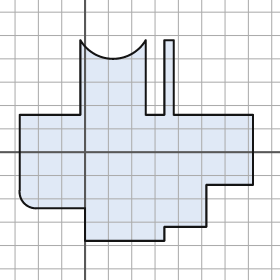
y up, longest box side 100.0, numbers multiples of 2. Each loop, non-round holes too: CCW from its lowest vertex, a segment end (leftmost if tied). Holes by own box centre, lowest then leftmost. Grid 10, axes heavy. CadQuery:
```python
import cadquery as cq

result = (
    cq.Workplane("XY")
    .moveTo(0.0, -38.0)
    .lineTo(34.0, -38.0)
    .lineTo(34.0, -32.0)
    .lineTo(52.0, -32.0)
    .lineTo(52.0, -14.0)
    .lineTo(72.0, -14.0)
    .lineTo(72.0, 16.0)
    .lineTo(38.0, 16.0)
    .lineTo(38.0, 48.0)
    .lineTo(34.0, 48.0)
    .lineTo(34.0, 16.0)
    .lineTo(26.0, 16.0)
    .lineTo(26.0, 48.0)
    .threePointArc((12.0, 40.0), (-2.0, 48.0))
    .lineTo(-2.0, 16.0)
    .lineTo(-28.0, 16.0)
    .lineTo(-28.0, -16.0)
    .threePointArc((-26.0, -22.0), (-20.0, -24.0))
    .lineTo(0.0, -24.0)
    .close()
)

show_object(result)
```